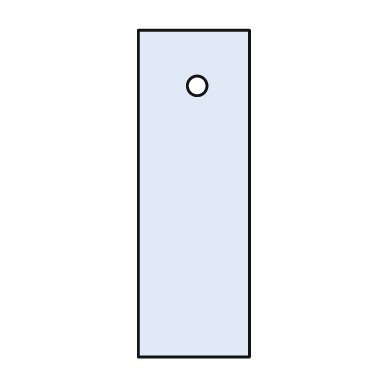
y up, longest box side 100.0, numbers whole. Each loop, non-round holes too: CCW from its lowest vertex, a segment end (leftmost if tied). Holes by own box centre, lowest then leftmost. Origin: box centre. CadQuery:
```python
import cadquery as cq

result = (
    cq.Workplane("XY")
    .moveTo(-17.0, -50.0)
    .lineTo(17.0, -50.0)
    .lineTo(17.0, 50.0)
    .lineTo(-17.0, 50.0)
    .close()
    .moveTo(1.0, 33.0)
    .circle(3.0)
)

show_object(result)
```